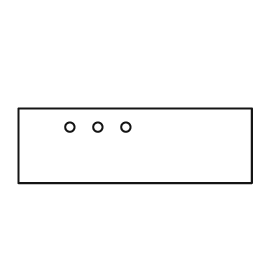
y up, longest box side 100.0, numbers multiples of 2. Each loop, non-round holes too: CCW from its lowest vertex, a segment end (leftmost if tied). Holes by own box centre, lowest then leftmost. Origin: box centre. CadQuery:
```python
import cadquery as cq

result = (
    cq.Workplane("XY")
    .moveTo(-50.0, -16.0)
    .lineTo(50.0, -16.0)
    .lineTo(50.0, 16.0)
    .lineTo(-50.0, 16.0)
    .close()
    .moveTo(-28.0, 8.0)
    .circle(2.0)
    .moveTo(-16.0, 8.0)
    .circle(2.0)
    .moveTo(-4.0, 8.0)
    .circle(2.0)
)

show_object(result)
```